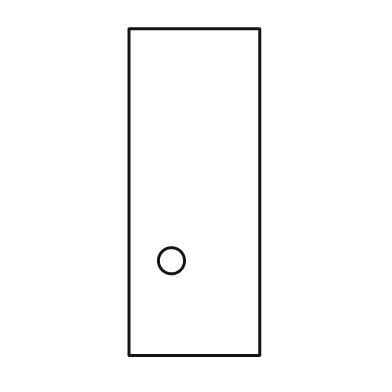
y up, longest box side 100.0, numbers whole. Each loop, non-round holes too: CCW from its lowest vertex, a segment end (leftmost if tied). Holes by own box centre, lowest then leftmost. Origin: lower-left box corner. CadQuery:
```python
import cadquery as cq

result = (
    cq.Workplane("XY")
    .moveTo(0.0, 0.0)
    .lineTo(40.0, 0.0)
    .lineTo(40.0, 100.0)
    .lineTo(0.0, 100.0)
    .close()
    .moveTo(13.0, 29.0)
    .circle(4.0)
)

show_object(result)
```